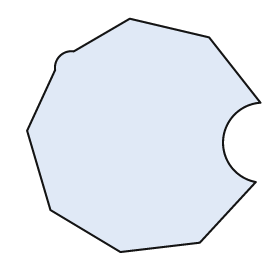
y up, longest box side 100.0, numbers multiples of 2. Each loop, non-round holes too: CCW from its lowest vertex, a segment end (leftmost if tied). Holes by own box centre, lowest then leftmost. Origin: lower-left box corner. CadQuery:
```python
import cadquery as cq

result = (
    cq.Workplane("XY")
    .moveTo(40.0, 0.0)
    .lineTo(74.0, 4.0)
    .lineTo(98.0, 30.0)
    .threePointArc((84.0, 48.0), (100.0, 64.0))
    .lineTo(78.0, 92.0)
    .lineTo(44.0, 100.0)
    .lineTo(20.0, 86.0)
    .threePointArc((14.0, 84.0), (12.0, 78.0))
    .lineTo(0.0, 52.0)
    .lineTo(10.0, 18.0)
    .close()
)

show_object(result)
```